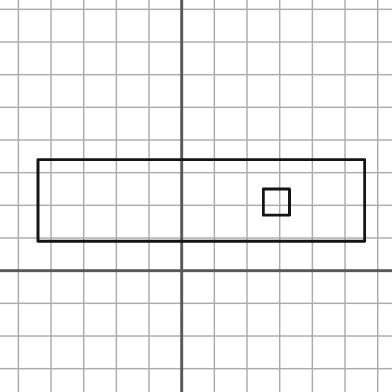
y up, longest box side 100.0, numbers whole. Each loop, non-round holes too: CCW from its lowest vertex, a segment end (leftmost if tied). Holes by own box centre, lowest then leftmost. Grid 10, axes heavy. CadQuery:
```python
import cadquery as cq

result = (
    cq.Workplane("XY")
    .moveTo(-44.0, 9.0)
    .lineTo(56.0, 9.0)
    .lineTo(56.0, 34.0)
    .lineTo(-44.0, 34.0)
    .close()
    .moveTo(25.0, 17.0)
    .lineTo(33.0, 17.0)
    .lineTo(33.0, 25.0)
    .lineTo(25.0, 25.0)
    .close()
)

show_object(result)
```